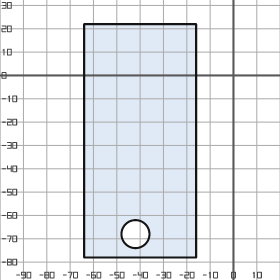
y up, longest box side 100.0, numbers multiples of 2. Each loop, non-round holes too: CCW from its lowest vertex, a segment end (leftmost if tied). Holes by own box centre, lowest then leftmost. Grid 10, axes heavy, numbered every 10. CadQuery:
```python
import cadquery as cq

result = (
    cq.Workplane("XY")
    .moveTo(-64.0, -78.0)
    .lineTo(-16.0, -78.0)
    .lineTo(-16.0, 22.0)
    .lineTo(-64.0, 22.0)
    .close()
    .moveTo(-42.0, -68.0)
    .circle(6.0)
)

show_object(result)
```